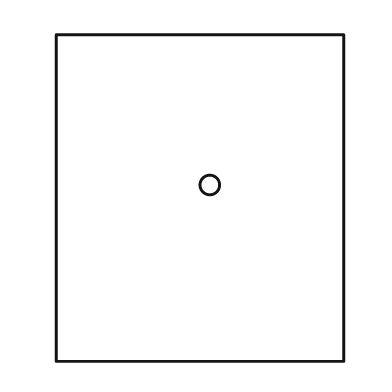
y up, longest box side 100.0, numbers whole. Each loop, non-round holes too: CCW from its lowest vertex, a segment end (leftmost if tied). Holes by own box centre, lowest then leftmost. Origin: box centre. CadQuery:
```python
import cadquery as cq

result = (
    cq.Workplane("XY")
    .moveTo(-44.0, -50.0)
    .lineTo(44.0, -50.0)
    .lineTo(44.0, 50.0)
    .lineTo(-44.0, 50.0)
    .close()
    .moveTo(3.0, 4.0)
    .circle(3.0)
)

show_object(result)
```